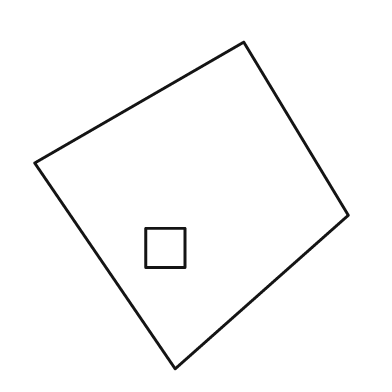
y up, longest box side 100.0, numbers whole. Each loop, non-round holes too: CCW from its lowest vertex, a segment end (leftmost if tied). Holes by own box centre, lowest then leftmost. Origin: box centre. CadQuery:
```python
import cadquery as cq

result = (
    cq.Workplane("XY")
    .moveTo(-5.0, -50.0)
    .lineTo(48.0, -3.0)
    .lineTo(16.0, 50.0)
    .lineTo(-48.0, 13.0)
    .close()
    .moveTo(-14.0, -19.0)
    .lineTo(-2.0, -19.0)
    .lineTo(-2.0, -7.0)
    .lineTo(-14.0, -7.0)
    .close()
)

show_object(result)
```